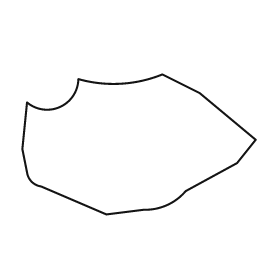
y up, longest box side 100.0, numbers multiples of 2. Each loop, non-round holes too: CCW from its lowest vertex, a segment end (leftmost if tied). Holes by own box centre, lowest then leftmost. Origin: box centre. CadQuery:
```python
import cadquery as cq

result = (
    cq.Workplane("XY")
    .moveTo(-14.0, -30.0)
    .lineTo(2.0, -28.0)
    .threePointArc((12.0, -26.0), (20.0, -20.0))
    .lineTo(42.0, -8.0)
    .lineTo(50.0, 2.0)
    .lineTo(26.0, 22.0)
    .lineTo(10.0, 30.0)
    .threePointArc((-8.0, 26.0), (-26.0, 28.0))
    .threePointArc((-34.0, 16.0), (-48.0, 18.0))
    .lineTo(-50.0, -2.0)
    .lineTo(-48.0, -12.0)
    .threePointArc((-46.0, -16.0), (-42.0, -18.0))
    .close()
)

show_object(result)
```